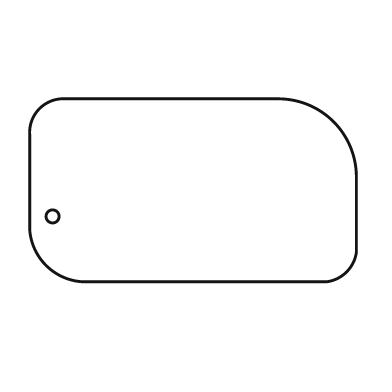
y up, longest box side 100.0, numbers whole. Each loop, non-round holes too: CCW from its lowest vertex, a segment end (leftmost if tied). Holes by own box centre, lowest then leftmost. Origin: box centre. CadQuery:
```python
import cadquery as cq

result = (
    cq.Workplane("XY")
    .moveTo(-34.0, -28.0)
    .lineTo(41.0, -28.0)
    .threePointArc((47.0, -25.0), (50.0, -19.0))
    .lineTo(50.0, 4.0)
    .threePointArc((43.0, 21.0), (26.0, 28.0))
    .lineTo(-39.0, 28.0)
    .threePointArc((-47.0, 25.0), (-50.0, 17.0))
    .lineTo(-50.0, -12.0)
    .threePointArc((-45.0, -23.0), (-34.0, -28.0))
    .close()
    .moveTo(-43.0, -8.0)
    .circle(2.0)
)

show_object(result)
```